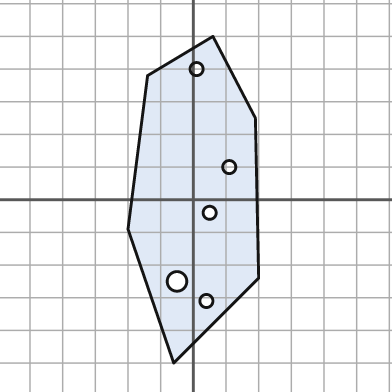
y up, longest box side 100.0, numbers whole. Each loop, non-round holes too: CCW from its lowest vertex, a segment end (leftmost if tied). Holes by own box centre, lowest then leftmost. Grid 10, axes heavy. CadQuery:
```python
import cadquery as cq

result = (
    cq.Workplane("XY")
    .moveTo(-6.0, -50.0)
    .lineTo(20.0, -24.0)
    .lineTo(19.0, 25.0)
    .lineTo(6.0, 50.0)
    .lineTo(-14.0, 38.0)
    .lineTo(-20.0, -9.0)
    .close()
    .moveTo(4.0, -31.0)
    .circle(2.0)
    .moveTo(-5.0, -25.0)
    .circle(3.0)
    .moveTo(5.0, -4.0)
    .circle(2.0)
    .moveTo(11.0, 10.0)
    .circle(2.0)
    .moveTo(1.0, 40.0)
    .circle(2.0)
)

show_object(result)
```